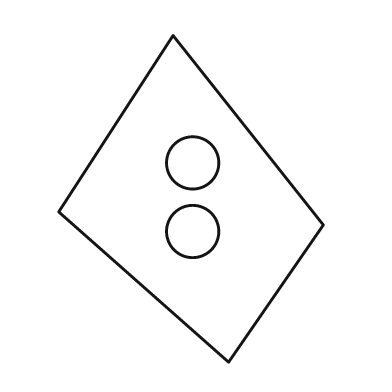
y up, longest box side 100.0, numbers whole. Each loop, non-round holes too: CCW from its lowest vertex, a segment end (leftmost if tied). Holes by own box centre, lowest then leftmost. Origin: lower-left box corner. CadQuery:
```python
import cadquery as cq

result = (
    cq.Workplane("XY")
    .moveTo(52.0, 0.0)
    .lineTo(81.0, 42.0)
    .lineTo(35.0, 100.0)
    .lineTo(0.0, 46.0)
    .close()
    .moveTo(41.0, 40.0)
    .circle(8.0)
    .moveTo(41.0, 61.0)
    .circle(8.0)
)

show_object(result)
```